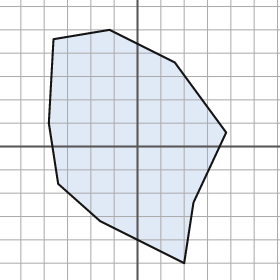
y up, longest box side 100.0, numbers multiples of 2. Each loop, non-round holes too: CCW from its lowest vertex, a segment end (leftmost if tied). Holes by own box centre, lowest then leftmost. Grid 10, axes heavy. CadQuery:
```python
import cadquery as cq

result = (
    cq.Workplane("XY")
    .moveTo(20.0, -50.0)
    .lineTo(24.0, -24.0)
    .lineTo(38.0, 6.0)
    .lineTo(16.0, 36.0)
    .lineTo(-12.0, 50.0)
    .lineTo(-36.0, 46.0)
    .lineTo(-38.0, 10.0)
    .lineTo(-34.0, -16.0)
    .lineTo(-16.0, -32.0)
    .close()
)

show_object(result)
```